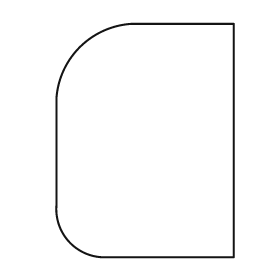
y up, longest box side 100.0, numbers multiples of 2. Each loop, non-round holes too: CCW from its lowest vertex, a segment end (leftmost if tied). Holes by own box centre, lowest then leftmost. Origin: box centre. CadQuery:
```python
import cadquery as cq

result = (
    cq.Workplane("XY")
    .moveTo(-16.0, -50.0)
    .lineTo(38.0, -50.0)
    .lineTo(38.0, 50.0)
    .lineTo(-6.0, 50.0)
    .threePointArc((-28.0, 40.0), (-38.0, 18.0))
    .lineTo(-38.0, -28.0)
    .threePointArc((-32.0, -44.0), (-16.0, -50.0))
    .close()
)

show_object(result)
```